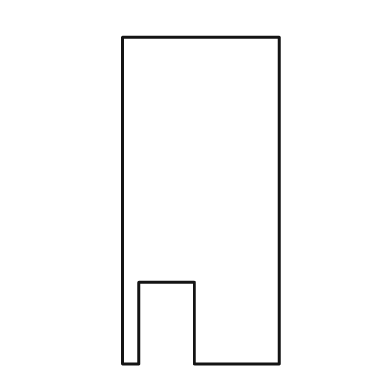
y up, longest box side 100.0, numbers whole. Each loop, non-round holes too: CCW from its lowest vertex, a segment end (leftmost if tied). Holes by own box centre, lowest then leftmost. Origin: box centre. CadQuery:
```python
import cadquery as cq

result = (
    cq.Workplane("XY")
    .moveTo(-24.0, -50.0)
    .lineTo(-19.0, -50.0)
    .lineTo(-19.0, -25.0)
    .lineTo(-2.0, -25.0)
    .lineTo(-2.0, -50.0)
    .lineTo(24.0, -50.0)
    .lineTo(24.0, 50.0)
    .lineTo(-24.0, 50.0)
    .close()
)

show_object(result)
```